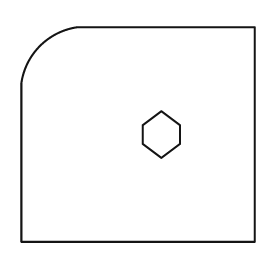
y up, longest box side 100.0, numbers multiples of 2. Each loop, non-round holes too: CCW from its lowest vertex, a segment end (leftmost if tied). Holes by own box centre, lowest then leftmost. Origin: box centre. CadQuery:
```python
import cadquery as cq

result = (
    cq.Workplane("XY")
    .moveTo(-50.0, -46.0)
    .lineTo(50.0, -46.0)
    .lineTo(50.0, 46.0)
    .lineTo(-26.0, 46.0)
    .threePointArc((-42.0, 38.0), (-50.0, 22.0))
    .close()
    .moveTo(10.0, -10.0)
    .lineTo(18.0, -4.0)
    .lineTo(18.0, 4.0)
    .lineTo(10.0, 10.0)
    .lineTo(2.0, 4.0)
    .lineTo(2.0, -4.0)
    .close()
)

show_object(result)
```